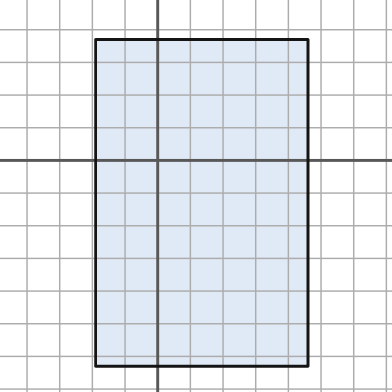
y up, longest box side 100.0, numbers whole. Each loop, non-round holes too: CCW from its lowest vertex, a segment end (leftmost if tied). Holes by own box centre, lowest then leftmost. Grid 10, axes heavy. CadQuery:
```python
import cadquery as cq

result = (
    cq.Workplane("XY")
    .moveTo(-19.0, -63.0)
    .lineTo(46.0, -63.0)
    .lineTo(46.0, 37.0)
    .lineTo(-19.0, 37.0)
    .close()
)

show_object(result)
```